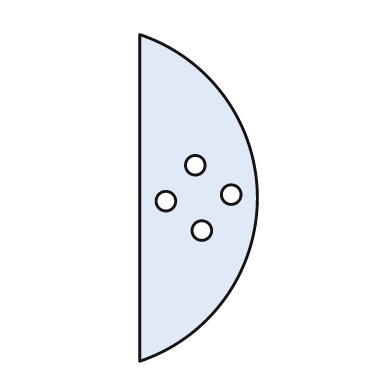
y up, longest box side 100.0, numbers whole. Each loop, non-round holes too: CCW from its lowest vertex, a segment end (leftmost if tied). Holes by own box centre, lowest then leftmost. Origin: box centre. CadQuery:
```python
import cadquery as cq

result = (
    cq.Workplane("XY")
    .moveTo(-18.0, -50.0)
    .threePointArc((18.0, 0.0), (-18.0, 50.0))
    .close()
    .moveTo(1.0, -10.0)
    .circle(3.0)
    .moveTo(-10.0, -1.0)
    .circle(3.0)
    .moveTo(10.0, 1.0)
    .circle(3.0)
    .moveTo(-1.0, 10.0)
    .circle(3.0)
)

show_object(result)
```